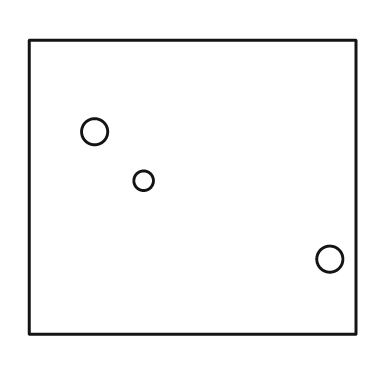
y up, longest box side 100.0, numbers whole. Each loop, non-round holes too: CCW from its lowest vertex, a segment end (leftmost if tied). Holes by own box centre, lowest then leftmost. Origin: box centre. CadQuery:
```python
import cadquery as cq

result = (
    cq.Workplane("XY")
    .moveTo(-50.0, -45.0)
    .lineTo(50.0, -45.0)
    .lineTo(50.0, 45.0)
    .lineTo(-50.0, 45.0)
    .close()
    .moveTo(42.0, -22.0)
    .circle(4.0)
    .moveTo(-15.0, 2.0)
    .circle(3.0)
    .moveTo(-30.0, 17.0)
    .circle(4.0)
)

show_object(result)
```